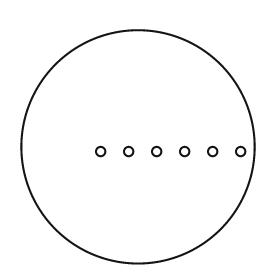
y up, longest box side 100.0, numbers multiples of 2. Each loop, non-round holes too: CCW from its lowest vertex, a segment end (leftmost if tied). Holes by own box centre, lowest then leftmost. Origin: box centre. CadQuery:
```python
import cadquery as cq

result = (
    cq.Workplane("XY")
    .moveTo(0.0, 0.0)
    .circle(50.0)
    .moveTo(-16.0, -2.0)
    .circle(2.0)
    .moveTo(-4.0, -2.0)
    .circle(2.0)
    .moveTo(8.0, -2.0)
    .circle(2.0)
    .moveTo(20.0, -2.0)
    .circle(2.0)
    .moveTo(32.0, -2.0)
    .circle(2.0)
    .moveTo(44.0, -2.0)
    .circle(2.0)
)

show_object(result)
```